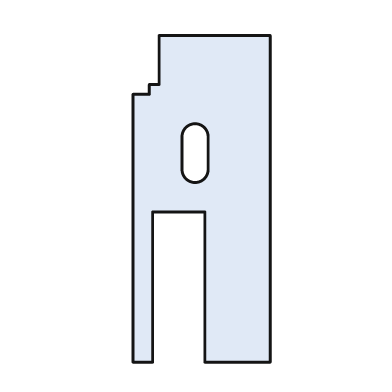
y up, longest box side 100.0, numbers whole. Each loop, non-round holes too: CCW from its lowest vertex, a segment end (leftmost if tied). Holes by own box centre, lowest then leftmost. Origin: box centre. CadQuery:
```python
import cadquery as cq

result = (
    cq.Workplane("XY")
    .moveTo(-21.0, -50.0)
    .lineTo(-15.0, -50.0)
    .lineTo(-15.0, -4.0)
    .lineTo(1.0, -4.0)
    .lineTo(1.0, -50.0)
    .lineTo(21.0, -50.0)
    .lineTo(21.0, 50.0)
    .lineTo(-13.0, 50.0)
    .lineTo(-13.0, 35.0)
    .lineTo(-16.0, 35.0)
    .lineTo(-16.0, 32.0)
    .lineTo(-21.0, 32.0)
    .close()
    .moveTo(-6.0, 9.0)
    .threePointArc((-2.0, 5.0), (2.0, 9.0))
    .lineTo(2.0, 19.0)
    .threePointArc((-2.0, 23.0), (-6.0, 19.0))
    .close()
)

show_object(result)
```